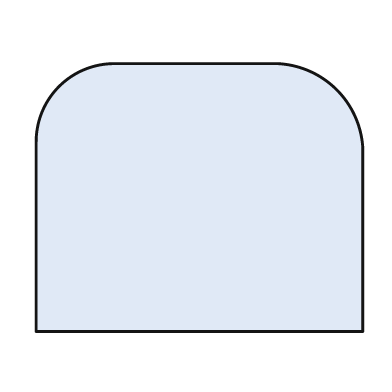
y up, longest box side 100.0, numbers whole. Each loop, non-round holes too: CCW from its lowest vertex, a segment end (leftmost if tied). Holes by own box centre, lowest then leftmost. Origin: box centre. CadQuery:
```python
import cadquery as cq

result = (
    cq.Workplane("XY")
    .moveTo(-50.0, -41.0)
    .lineTo(50.0, -41.0)
    .lineTo(50.0, 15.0)
    .threePointArc((42.0, 33.0), (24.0, 41.0))
    .lineTo(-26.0, 41.0)
    .threePointArc((-43.0, 34.0), (-50.0, 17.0))
    .close()
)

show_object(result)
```